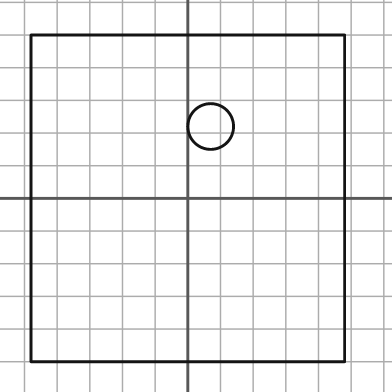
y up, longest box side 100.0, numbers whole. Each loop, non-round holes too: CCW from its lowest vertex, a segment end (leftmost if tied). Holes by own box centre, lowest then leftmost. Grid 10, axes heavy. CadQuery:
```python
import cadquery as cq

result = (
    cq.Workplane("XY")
    .moveTo(-48.0, -50.0)
    .lineTo(48.0, -50.0)
    .lineTo(48.0, 50.0)
    .lineTo(-48.0, 50.0)
    .close()
    .moveTo(7.0, 22.0)
    .circle(7.0)
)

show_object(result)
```